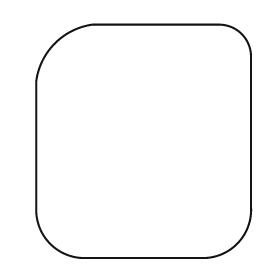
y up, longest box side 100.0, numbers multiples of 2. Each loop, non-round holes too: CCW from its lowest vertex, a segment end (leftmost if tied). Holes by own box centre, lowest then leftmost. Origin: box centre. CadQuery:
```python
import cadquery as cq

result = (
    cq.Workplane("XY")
    .moveTo(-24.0, -50.0)
    .lineTo(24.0, -50.0)
    .threePointArc((40.0, -44.0), (46.0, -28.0))
    .lineTo(46.0, 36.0)
    .threePointArc((42.0, 46.0), (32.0, 50.0))
    .lineTo(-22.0, 50.0)
    .threePointArc((-38.0, 42.0), (-46.0, 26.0))
    .lineTo(-46.0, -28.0)
    .threePointArc((-40.0, -44.0), (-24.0, -50.0))
    .close()
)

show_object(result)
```